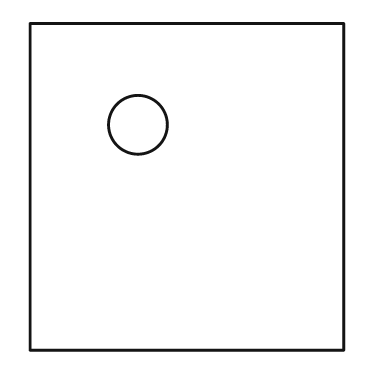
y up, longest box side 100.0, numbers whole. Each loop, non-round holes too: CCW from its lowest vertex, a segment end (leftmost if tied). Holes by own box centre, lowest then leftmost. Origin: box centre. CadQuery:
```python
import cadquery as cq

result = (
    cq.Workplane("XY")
    .moveTo(-48.0, -50.0)
    .lineTo(48.0, -50.0)
    .lineTo(48.0, 50.0)
    .lineTo(-48.0, 50.0)
    .close()
    .moveTo(-15.0, 19.0)
    .circle(9.0)
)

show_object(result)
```